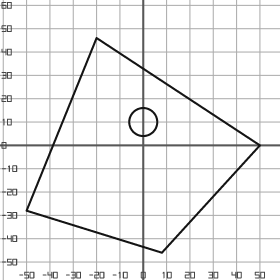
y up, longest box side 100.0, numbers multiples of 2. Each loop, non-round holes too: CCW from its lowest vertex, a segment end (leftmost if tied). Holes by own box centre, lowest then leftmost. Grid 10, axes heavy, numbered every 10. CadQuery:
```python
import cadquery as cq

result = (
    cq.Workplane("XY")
    .moveTo(8.0, -46.0)
    .lineTo(50.0, 0.0)
    .lineTo(-20.0, 46.0)
    .lineTo(-50.0, -28.0)
    .close()
    .moveTo(0.0, 10.0)
    .circle(6.0)
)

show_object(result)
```